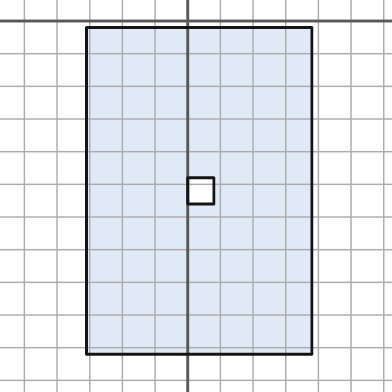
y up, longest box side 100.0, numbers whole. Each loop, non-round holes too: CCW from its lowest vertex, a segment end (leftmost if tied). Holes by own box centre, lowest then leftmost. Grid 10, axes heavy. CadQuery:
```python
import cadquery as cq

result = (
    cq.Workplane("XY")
    .moveTo(-31.0, -102.0)
    .lineTo(38.0, -102.0)
    .lineTo(38.0, -2.0)
    .lineTo(-31.0, -2.0)
    .close()
    .moveTo(0.0, -56.0)
    .lineTo(8.0, -56.0)
    .lineTo(8.0, -48.0)
    .lineTo(0.0, -48.0)
    .close()
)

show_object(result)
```